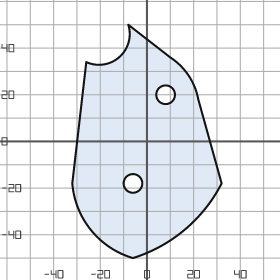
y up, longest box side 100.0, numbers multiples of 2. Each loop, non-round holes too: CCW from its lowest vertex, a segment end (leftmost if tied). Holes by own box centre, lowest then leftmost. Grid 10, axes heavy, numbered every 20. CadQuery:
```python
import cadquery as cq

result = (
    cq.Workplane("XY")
    .moveTo(-6.0, -50.0)
    .threePointArc((16.0, -38.0), (32.0, -18.0))
    .lineTo(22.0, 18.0)
    .threePointArc((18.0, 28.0), (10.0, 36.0))
    .lineTo(-8.0, 50.0)
    .threePointArc((-12.0, 36.0), (-26.0, 34.0))
    .lineTo(-32.0, -18.0)
    .threePointArc((-24.0, -38.0), (-6.0, -50.0))
    .close()
    .moveTo(-6.0, -18.0)
    .circle(4.0)
    .moveTo(8.0, 20.0)
    .circle(4.0)
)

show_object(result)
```